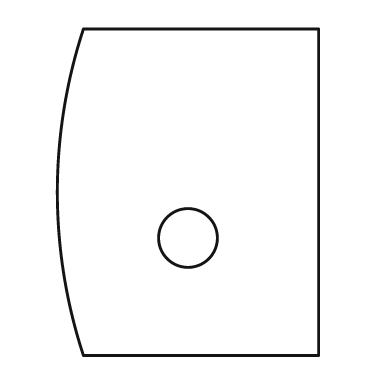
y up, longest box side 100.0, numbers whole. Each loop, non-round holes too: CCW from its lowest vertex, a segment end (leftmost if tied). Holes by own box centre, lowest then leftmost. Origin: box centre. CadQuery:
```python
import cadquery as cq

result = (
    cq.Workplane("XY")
    .moveTo(-32.0, -50.0)
    .lineTo(40.0, -50.0)
    .lineTo(40.0, 50.0)
    .lineTo(-32.0, 50.0)
    .threePointArc((-40.0, 0.0), (-32.0, -50.0))
    .close()
    .moveTo(0.0, -14.0)
    .circle(9.0)
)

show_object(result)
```